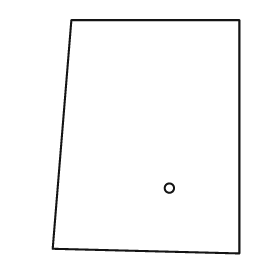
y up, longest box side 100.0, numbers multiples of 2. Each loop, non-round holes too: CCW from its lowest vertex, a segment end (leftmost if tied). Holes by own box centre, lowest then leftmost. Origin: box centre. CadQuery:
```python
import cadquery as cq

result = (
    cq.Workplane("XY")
    .moveTo(40.0, -50.0)
    .lineTo(40.0, 50.0)
    .lineTo(-32.0, 50.0)
    .lineTo(-40.0, -48.0)
    .close()
    .moveTo(10.0, -22.0)
    .circle(2.0)
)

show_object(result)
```